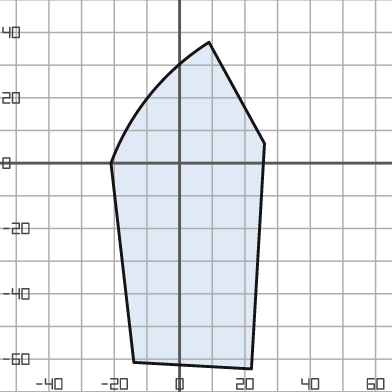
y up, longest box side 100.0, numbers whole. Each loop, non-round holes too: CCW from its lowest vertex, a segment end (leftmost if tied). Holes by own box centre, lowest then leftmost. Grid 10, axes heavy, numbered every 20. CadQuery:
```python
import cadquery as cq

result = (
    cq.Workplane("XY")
    .moveTo(22.0, -63.0)
    .lineTo(26.0, 6.0)
    .lineTo(9.0, 37.0)
    .threePointArc((-9.0, 21.0), (-21.0, 0.0))
    .lineTo(-14.0, -61.0)
    .close()
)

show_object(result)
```